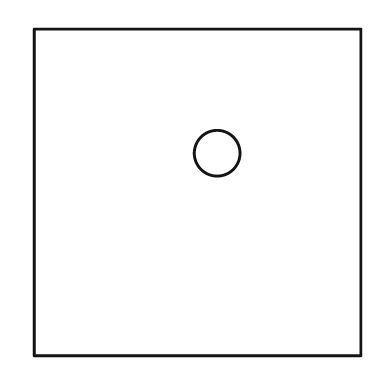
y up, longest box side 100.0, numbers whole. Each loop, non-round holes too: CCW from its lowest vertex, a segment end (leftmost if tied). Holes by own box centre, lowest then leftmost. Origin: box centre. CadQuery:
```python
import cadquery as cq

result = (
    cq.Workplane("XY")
    .moveTo(-50.0, -50.0)
    .lineTo(50.0, -50.0)
    .lineTo(50.0, 50.0)
    .lineTo(-50.0, 50.0)
    .close()
    .moveTo(6.0, 12.0)
    .circle(7.0)
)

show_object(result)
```